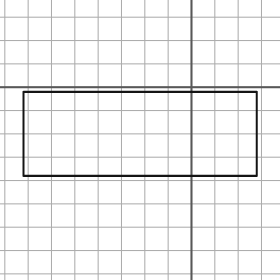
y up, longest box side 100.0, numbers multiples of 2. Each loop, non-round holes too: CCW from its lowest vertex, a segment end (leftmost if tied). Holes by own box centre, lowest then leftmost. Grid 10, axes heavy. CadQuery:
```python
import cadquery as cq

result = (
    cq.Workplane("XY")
    .moveTo(-72.0, -38.0)
    .lineTo(28.0, -38.0)
    .lineTo(28.0, -2.0)
    .lineTo(-72.0, -2.0)
    .close()
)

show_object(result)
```